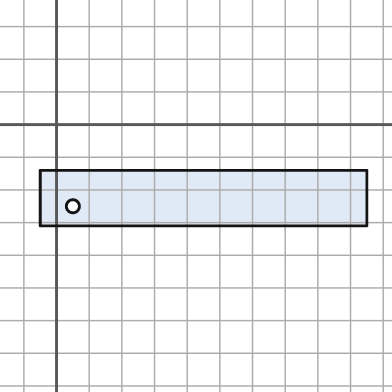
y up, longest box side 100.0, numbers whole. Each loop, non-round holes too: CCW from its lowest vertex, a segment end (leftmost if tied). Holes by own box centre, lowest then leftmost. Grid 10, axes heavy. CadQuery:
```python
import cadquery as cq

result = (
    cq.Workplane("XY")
    .moveTo(-5.0, -31.0)
    .lineTo(95.0, -31.0)
    .lineTo(95.0, -14.0)
    .lineTo(-5.0, -14.0)
    .close()
    .moveTo(5.0, -25.0)
    .circle(2.0)
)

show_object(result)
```